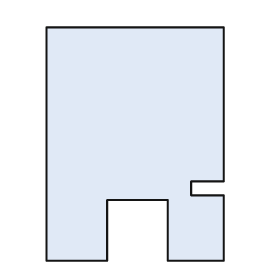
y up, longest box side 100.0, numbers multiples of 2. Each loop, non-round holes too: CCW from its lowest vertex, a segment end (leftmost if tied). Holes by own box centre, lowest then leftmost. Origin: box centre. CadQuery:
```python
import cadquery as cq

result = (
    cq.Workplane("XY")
    .moveTo(-38.0, -50.0)
    .lineTo(-12.0, -50.0)
    .lineTo(-12.0, -24.0)
    .lineTo(14.0, -24.0)
    .lineTo(14.0, -50.0)
    .lineTo(38.0, -50.0)
    .lineTo(38.0, -22.0)
    .lineTo(24.0, -22.0)
    .lineTo(24.0, -16.0)
    .lineTo(38.0, -16.0)
    .lineTo(38.0, 50.0)
    .lineTo(-38.0, 50.0)
    .close()
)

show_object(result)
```